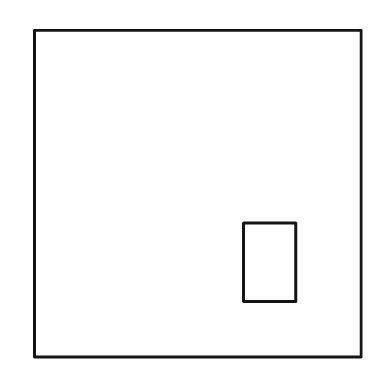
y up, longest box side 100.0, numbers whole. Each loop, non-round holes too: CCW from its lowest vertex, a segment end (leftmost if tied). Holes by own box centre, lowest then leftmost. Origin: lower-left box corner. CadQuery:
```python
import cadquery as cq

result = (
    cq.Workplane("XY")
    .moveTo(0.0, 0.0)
    .lineTo(100.0, 0.0)
    .lineTo(100.0, 100.0)
    .lineTo(0.0, 100.0)
    .close()
    .moveTo(64.0, 17.0)
    .lineTo(80.0, 17.0)
    .lineTo(80.0, 41.0)
    .lineTo(64.0, 41.0)
    .close()
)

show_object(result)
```